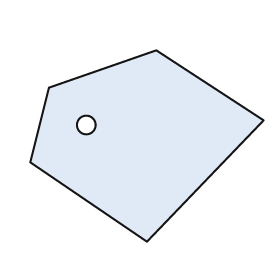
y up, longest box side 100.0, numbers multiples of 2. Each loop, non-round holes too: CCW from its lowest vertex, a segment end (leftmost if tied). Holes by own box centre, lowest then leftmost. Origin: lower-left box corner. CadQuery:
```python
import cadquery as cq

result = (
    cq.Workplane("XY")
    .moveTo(50.0, 0.0)
    .lineTo(100.0, 52.0)
    .lineTo(54.0, 82.0)
    .lineTo(8.0, 66.0)
    .lineTo(0.0, 34.0)
    .close()
    .moveTo(24.0, 50.0)
    .circle(4.0)
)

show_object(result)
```